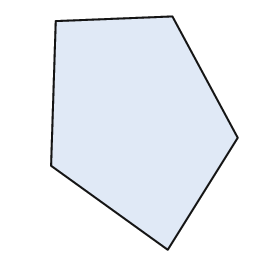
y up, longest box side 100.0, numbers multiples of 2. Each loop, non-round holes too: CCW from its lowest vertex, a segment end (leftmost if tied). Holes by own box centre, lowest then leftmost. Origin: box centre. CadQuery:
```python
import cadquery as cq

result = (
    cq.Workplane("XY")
    .moveTo(10.0, -50.0)
    .lineTo(40.0, -2.0)
    .lineTo(12.0, 50.0)
    .lineTo(-38.0, 48.0)
    .lineTo(-40.0, -14.0)
    .close()
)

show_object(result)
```